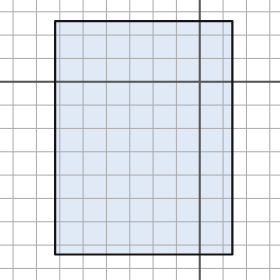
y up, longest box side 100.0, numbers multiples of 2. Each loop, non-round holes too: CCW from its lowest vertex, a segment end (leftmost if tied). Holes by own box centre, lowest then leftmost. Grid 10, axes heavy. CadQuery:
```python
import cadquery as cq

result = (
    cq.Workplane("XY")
    .moveTo(-62.0, -74.0)
    .lineTo(14.0, -74.0)
    .lineTo(14.0, 26.0)
    .lineTo(-62.0, 26.0)
    .close()
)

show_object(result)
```